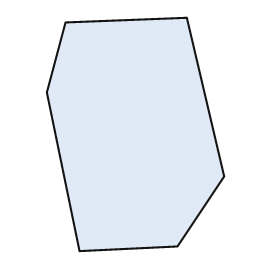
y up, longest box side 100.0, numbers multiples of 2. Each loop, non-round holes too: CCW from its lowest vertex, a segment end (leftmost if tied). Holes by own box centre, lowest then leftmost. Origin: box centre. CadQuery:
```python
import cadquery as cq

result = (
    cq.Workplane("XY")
    .moveTo(-24.0, -50.0)
    .lineTo(18.0, -48.0)
    .lineTo(38.0, -18.0)
    .lineTo(22.0, 50.0)
    .lineTo(-30.0, 48.0)
    .lineTo(-38.0, 18.0)
    .close()
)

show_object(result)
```